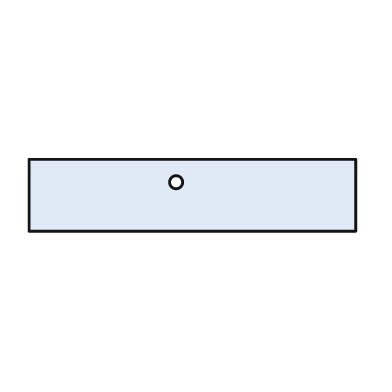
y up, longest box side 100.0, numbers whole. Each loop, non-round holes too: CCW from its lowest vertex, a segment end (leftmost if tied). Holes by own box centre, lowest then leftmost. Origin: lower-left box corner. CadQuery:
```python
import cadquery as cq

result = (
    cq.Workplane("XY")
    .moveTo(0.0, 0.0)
    .lineTo(100.0, 0.0)
    .lineTo(100.0, 22.0)
    .lineTo(0.0, 22.0)
    .close()
    .moveTo(45.0, 15.0)
    .circle(2.0)
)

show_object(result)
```